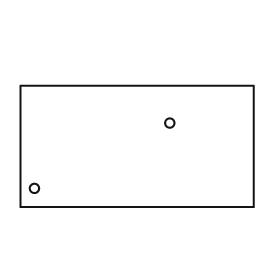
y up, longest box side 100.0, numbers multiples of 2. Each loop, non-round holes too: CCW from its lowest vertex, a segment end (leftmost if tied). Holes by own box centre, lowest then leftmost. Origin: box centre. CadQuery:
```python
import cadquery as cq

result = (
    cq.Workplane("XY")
    .moveTo(-50.0, -26.0)
    .lineTo(50.0, -26.0)
    .lineTo(50.0, 26.0)
    .lineTo(-50.0, 26.0)
    .close()
    .moveTo(-44.0, -18.0)
    .circle(2.0)
    .moveTo(14.0, 10.0)
    .circle(2.0)
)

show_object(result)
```